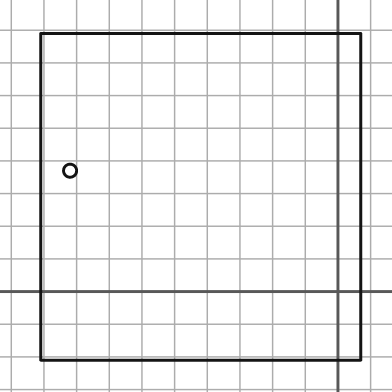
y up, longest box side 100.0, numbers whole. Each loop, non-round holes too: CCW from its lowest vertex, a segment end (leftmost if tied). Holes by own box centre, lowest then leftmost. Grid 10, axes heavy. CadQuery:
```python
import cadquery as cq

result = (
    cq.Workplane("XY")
    .moveTo(-91.0, -21.0)
    .lineTo(7.0, -21.0)
    .lineTo(7.0, 79.0)
    .lineTo(-91.0, 79.0)
    .close()
    .moveTo(-82.0, 37.0)
    .circle(2.0)
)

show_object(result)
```